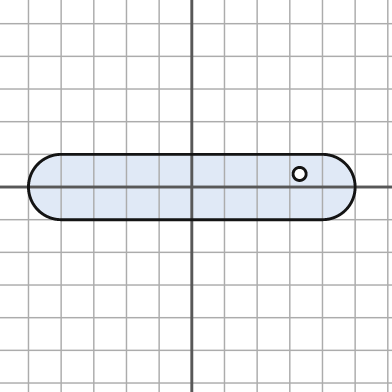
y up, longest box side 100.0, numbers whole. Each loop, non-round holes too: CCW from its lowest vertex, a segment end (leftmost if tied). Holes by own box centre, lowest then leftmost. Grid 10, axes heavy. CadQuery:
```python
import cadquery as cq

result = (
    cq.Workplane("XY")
    .moveTo(-40.0, -10.0)
    .lineTo(40.0, -10.0)
    .threePointArc((50.0, 0.0), (40.0, 10.0))
    .lineTo(-40.0, 10.0)
    .threePointArc((-50.0, 0.0), (-40.0, -10.0))
    .close()
    .moveTo(33.0, 4.0)
    .circle(2.0)
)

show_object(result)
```